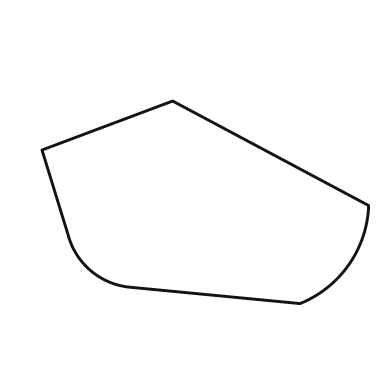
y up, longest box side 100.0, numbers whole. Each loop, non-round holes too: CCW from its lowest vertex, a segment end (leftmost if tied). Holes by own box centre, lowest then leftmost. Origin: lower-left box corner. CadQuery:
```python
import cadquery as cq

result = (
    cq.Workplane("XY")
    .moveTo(79.0, 0.0)
    .threePointArc((94.0, 12.0), (100.0, 30.0))
    .lineTo(40.0, 62.0)
    .lineTo(0.0, 47.0)
    .lineTo(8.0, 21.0)
    .threePointArc((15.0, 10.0), (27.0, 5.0))
    .close()
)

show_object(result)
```